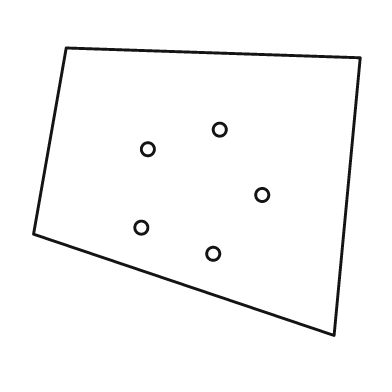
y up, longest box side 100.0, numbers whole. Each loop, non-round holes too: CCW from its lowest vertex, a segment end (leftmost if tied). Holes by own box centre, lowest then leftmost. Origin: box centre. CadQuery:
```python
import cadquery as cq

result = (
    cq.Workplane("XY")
    .moveTo(42.0, -44.0)
    .lineTo(50.0, 41.0)
    .lineTo(-40.0, 44.0)
    .lineTo(-50.0, -13.0)
    .close()
    .moveTo(5.0, -19.0)
    .circle(2.0)
    .moveTo(-17.0, -11.0)
    .circle(2.0)
    .moveTo(20.0, -1.0)
    .circle(2.0)
    .moveTo(-15.0, 13.0)
    .circle(2.0)
    .moveTo(7.0, 19.0)
    .circle(2.0)
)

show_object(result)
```